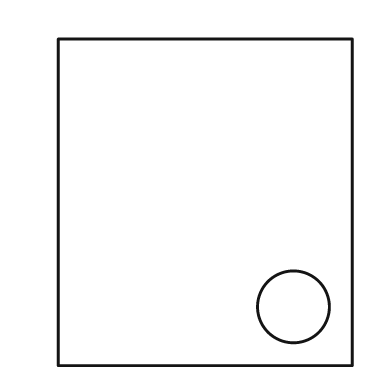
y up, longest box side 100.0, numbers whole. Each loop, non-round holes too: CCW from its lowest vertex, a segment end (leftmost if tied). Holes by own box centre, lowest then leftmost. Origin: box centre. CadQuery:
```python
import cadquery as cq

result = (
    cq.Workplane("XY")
    .moveTo(-45.0, -50.0)
    .lineTo(45.0, -50.0)
    .lineTo(45.0, 50.0)
    .lineTo(-45.0, 50.0)
    .close()
    .moveTo(27.0, -32.0)
    .circle(11.0)
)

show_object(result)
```